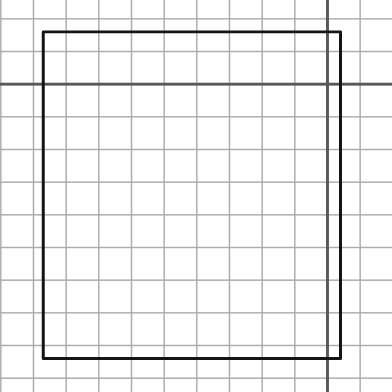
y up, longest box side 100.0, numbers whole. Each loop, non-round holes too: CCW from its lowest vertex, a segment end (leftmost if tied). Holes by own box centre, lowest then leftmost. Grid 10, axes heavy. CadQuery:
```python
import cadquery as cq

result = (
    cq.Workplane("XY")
    .moveTo(-87.0, -84.0)
    .lineTo(4.0, -84.0)
    .lineTo(4.0, 16.0)
    .lineTo(-87.0, 16.0)
    .close()
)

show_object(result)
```